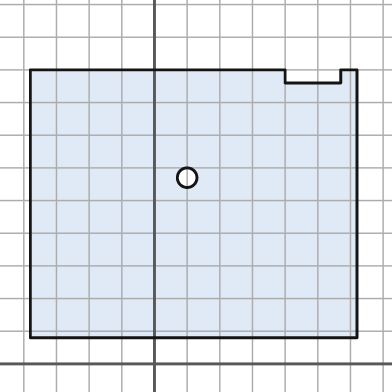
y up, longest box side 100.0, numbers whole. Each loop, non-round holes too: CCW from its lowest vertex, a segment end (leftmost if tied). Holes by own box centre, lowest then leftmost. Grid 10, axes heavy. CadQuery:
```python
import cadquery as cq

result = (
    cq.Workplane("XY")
    .moveTo(-38.0, 8.0)
    .lineTo(62.0, 8.0)
    .lineTo(62.0, 90.0)
    .lineTo(57.0, 90.0)
    .lineTo(57.0, 86.0)
    .lineTo(40.0, 86.0)
    .lineTo(40.0, 90.0)
    .lineTo(-38.0, 90.0)
    .close()
    .moveTo(10.0, 57.0)
    .circle(3.0)
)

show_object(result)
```